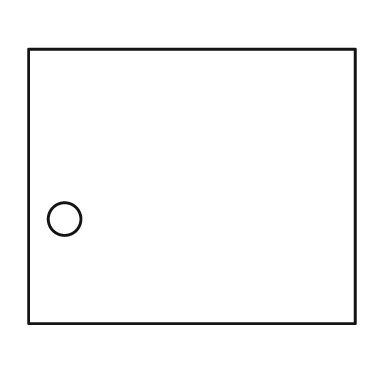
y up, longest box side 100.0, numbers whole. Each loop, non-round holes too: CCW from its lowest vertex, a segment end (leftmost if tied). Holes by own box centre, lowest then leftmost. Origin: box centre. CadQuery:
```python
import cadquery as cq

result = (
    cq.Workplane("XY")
    .moveTo(-50.0, -42.0)
    .lineTo(50.0, -42.0)
    .lineTo(50.0, 42.0)
    .lineTo(-50.0, 42.0)
    .close()
    .moveTo(-39.0, -10.0)
    .circle(5.0)
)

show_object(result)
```